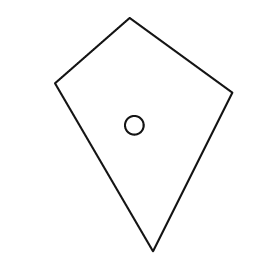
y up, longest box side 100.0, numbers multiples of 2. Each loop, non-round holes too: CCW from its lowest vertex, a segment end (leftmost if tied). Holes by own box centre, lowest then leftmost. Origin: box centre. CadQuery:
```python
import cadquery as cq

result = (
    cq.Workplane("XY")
    .moveTo(4.0, -50.0)
    .lineTo(38.0, 18.0)
    .lineTo(-6.0, 50.0)
    .lineTo(-38.0, 22.0)
    .close()
    .moveTo(-4.0, 4.0)
    .circle(4.0)
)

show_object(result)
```